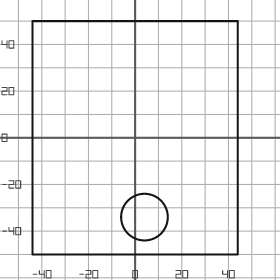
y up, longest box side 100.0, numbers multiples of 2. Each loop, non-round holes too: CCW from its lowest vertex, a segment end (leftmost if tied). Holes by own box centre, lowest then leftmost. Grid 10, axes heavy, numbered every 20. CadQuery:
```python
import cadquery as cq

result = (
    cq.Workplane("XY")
    .moveTo(-44.0, -50.0)
    .lineTo(44.0, -50.0)
    .lineTo(44.0, 50.0)
    .lineTo(-44.0, 50.0)
    .close()
    .moveTo(4.0, -34.0)
    .circle(10.0)
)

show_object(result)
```